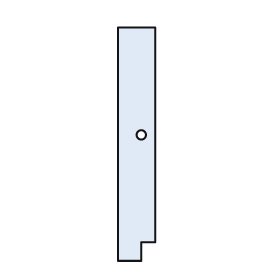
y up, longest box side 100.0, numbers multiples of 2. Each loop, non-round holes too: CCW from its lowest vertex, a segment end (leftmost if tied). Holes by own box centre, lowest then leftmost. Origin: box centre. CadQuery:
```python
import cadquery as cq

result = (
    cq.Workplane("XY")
    .moveTo(-8.0, -50.0)
    .lineTo(2.0, -50.0)
    .lineTo(2.0, -42.0)
    .lineTo(8.0, -42.0)
    .lineTo(8.0, 50.0)
    .lineTo(-8.0, 50.0)
    .close()
    .moveTo(2.0, 4.0)
    .circle(2.0)
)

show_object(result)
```